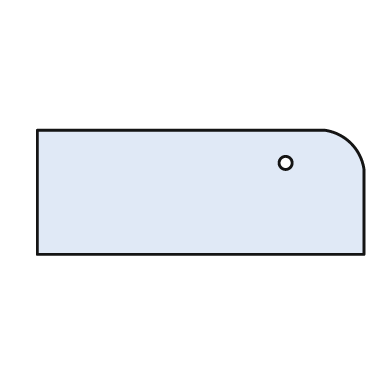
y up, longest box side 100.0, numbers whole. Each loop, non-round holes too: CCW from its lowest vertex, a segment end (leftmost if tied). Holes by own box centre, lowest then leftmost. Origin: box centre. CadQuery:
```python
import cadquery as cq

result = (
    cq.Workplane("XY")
    .moveTo(-50.0, -19.0)
    .lineTo(50.0, -19.0)
    .lineTo(50.0, 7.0)
    .threePointArc((46.0, 15.0), (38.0, 19.0))
    .lineTo(-50.0, 19.0)
    .close()
    .moveTo(26.0, 9.0)
    .circle(2.0)
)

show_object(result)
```